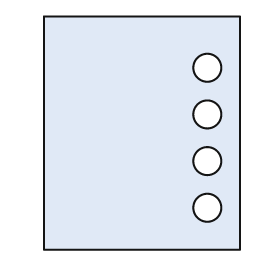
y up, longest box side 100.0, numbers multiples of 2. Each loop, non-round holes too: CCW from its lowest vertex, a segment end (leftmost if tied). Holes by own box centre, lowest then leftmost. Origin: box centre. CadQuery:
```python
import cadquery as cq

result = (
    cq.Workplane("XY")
    .moveTo(-42.0, -50.0)
    .lineTo(42.0, -50.0)
    .lineTo(42.0, 50.0)
    .lineTo(-42.0, 50.0)
    .close()
    .moveTo(28.0, -32.0)
    .circle(6.0)
    .moveTo(28.0, -12.0)
    .circle(6.0)
    .moveTo(28.0, 8.0)
    .circle(6.0)
    .moveTo(28.0, 28.0)
    .circle(6.0)
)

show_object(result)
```